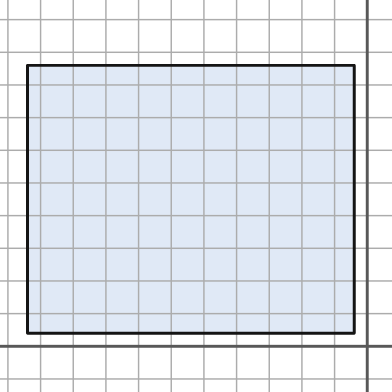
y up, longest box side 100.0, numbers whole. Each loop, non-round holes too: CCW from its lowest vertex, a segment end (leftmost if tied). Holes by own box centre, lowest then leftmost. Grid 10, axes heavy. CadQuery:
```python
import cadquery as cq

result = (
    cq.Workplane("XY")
    .moveTo(-104.0, 4.0)
    .lineTo(-4.0, 4.0)
    .lineTo(-4.0, 86.0)
    .lineTo(-104.0, 86.0)
    .close()
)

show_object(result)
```